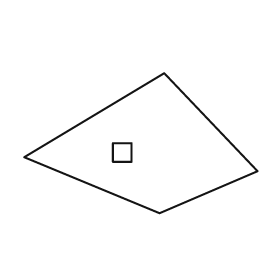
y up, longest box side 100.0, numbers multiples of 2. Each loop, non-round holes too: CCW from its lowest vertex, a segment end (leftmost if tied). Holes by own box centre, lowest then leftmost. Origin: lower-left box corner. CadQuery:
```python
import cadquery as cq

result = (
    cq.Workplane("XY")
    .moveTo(58.0, 0.0)
    .lineTo(100.0, 18.0)
    .lineTo(60.0, 60.0)
    .lineTo(0.0, 24.0)
    .close()
    .moveTo(38.0, 22.0)
    .lineTo(46.0, 22.0)
    .lineTo(46.0, 30.0)
    .lineTo(38.0, 30.0)
    .close()
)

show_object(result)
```